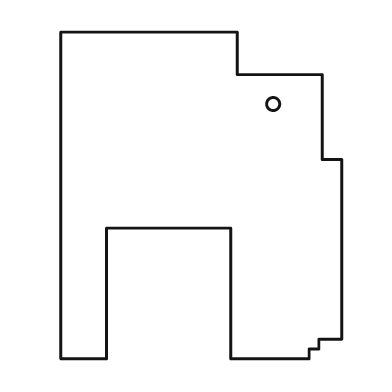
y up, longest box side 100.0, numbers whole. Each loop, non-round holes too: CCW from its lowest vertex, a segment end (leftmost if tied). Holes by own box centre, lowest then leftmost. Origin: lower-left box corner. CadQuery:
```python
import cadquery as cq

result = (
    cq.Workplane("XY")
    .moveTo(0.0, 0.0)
    .lineTo(14.0, 0.0)
    .lineTo(14.0, 40.0)
    .lineTo(52.0, 40.0)
    .lineTo(52.0, 0.0)
    .lineTo(76.0, 0.0)
    .lineTo(76.0, 3.0)
    .lineTo(79.0, 3.0)
    .lineTo(79.0, 6.0)
    .lineTo(86.0, 6.0)
    .lineTo(86.0, 61.0)
    .lineTo(80.0, 61.0)
    .lineTo(80.0, 87.0)
    .lineTo(54.0, 87.0)
    .lineTo(54.0, 100.0)
    .lineTo(0.0, 100.0)
    .close()
    .moveTo(65.0, 78.0)
    .circle(2.0)
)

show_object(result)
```